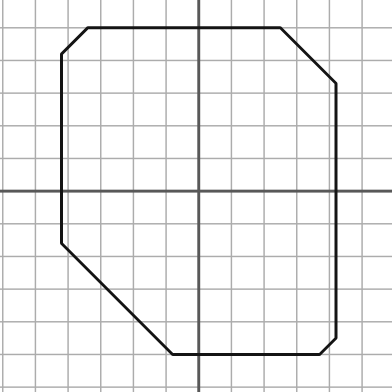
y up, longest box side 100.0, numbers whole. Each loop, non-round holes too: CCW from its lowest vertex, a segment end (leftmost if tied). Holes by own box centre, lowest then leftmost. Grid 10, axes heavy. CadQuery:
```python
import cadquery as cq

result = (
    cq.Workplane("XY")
    .moveTo(-8.0, -50.0)
    .lineTo(37.0, -50.0)
    .lineTo(42.0, -45.0)
    .lineTo(42.0, 33.0)
    .lineTo(25.0, 50.0)
    .lineTo(-34.0, 50.0)
    .lineTo(-42.0, 42.0)
    .lineTo(-42.0, -16.0)
    .close()
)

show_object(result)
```